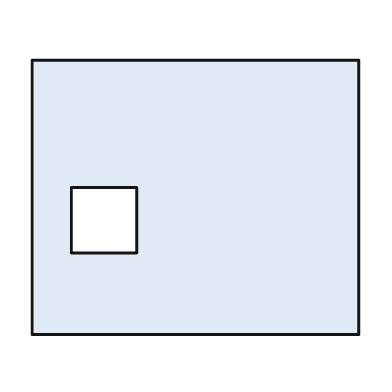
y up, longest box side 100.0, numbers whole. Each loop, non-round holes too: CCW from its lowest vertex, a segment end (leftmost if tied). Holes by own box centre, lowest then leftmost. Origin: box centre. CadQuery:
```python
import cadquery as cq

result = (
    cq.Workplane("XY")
    .moveTo(-50.0, -42.0)
    .lineTo(50.0, -42.0)
    .lineTo(50.0, 42.0)
    .lineTo(-50.0, 42.0)
    .close()
    .moveTo(-38.0, -17.0)
    .lineTo(-18.0, -17.0)
    .lineTo(-18.0, 3.0)
    .lineTo(-38.0, 3.0)
    .close()
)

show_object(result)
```